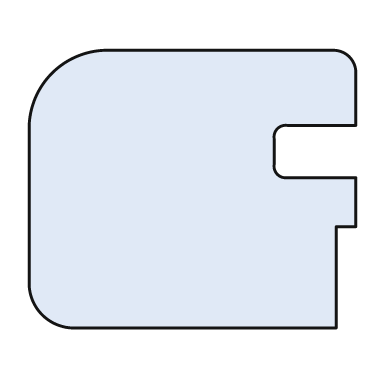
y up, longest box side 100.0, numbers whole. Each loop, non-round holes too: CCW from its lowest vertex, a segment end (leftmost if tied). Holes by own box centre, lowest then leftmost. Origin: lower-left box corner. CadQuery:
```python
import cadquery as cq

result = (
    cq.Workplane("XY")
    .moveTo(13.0, 0.0)
    .lineTo(94.0, 0.0)
    .lineTo(94.0, 31.0)
    .lineTo(100.0, 31.0)
    .lineTo(100.0, 46.0)
    .lineTo(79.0, 46.0)
    .threePointArc((76.0, 47.0), (75.0, 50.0))
    .lineTo(75.0, 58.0)
    .threePointArc((76.0, 61.0), (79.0, 62.0))
    .lineTo(100.0, 62.0)
    .lineTo(100.0, 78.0)
    .threePointArc((98.0, 83.0), (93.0, 85.0))
    .lineTo(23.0, 85.0)
    .threePointArc((7.0, 78.0), (0.0, 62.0))
    .lineTo(0.0, 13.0)
    .threePointArc((4.0, 4.0), (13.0, 0.0))
    .close()
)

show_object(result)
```